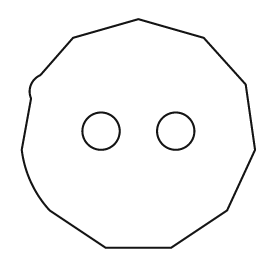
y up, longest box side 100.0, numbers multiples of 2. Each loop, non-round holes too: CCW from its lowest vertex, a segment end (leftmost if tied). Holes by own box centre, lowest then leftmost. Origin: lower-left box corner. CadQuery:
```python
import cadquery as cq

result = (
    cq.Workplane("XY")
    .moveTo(36.0, 0.0)
    .lineTo(64.0, 0.0)
    .lineTo(88.0, 16.0)
    .lineTo(100.0, 42.0)
    .lineTo(96.0, 70.0)
    .lineTo(78.0, 90.0)
    .lineTo(50.0, 98.0)
    .lineTo(22.0, 90.0)
    .lineTo(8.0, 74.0)
    .threePointArc((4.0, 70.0), (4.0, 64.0))
    .lineTo(0.0, 42.0)
    .threePointArc((4.0, 28.0), (12.0, 16.0))
    .close()
    .moveTo(34.0, 50.0)
    .circle(8.0)
    .moveTo(66.0, 50.0)
    .circle(8.0)
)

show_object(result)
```